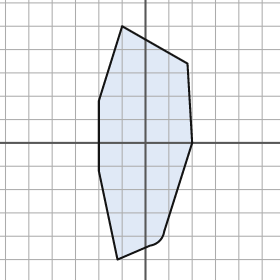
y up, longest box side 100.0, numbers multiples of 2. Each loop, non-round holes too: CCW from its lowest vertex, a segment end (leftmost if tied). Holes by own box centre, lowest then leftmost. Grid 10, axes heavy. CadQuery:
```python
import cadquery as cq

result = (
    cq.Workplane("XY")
    .moveTo(-12.0, -50.0)
    .lineTo(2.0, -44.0)
    .threePointArc((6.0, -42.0), (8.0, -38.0))
    .lineTo(20.0, 0.0)
    .lineTo(18.0, 34.0)
    .lineTo(-10.0, 50.0)
    .lineTo(-20.0, 18.0)
    .lineTo(-20.0, -12.0)
    .close()
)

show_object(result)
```